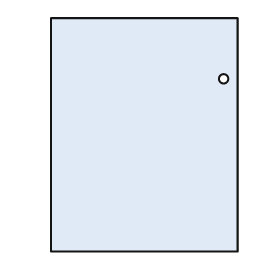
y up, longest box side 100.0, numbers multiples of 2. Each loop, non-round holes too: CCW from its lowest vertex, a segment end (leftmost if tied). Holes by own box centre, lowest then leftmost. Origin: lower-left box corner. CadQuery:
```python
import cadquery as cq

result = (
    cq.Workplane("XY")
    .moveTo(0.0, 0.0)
    .lineTo(80.0, 0.0)
    .lineTo(80.0, 100.0)
    .lineTo(0.0, 100.0)
    .close()
    .moveTo(74.0, 74.0)
    .circle(2.0)
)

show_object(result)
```